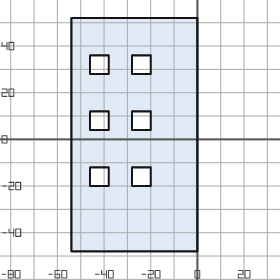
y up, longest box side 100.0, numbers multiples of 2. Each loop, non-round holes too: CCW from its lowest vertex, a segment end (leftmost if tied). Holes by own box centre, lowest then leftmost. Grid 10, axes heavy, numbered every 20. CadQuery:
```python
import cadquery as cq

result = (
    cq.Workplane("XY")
    .moveTo(-54.0, -48.0)
    .lineTo(0.0, -48.0)
    .lineTo(0.0, 52.0)
    .lineTo(-54.0, 52.0)
    .close()
    .moveTo(-46.0, -20.0)
    .lineTo(-38.0, -20.0)
    .lineTo(-38.0, -12.0)
    .lineTo(-46.0, -12.0)
    .close()
    .moveTo(-28.0, -20.0)
    .lineTo(-20.0, -20.0)
    .lineTo(-20.0, -12.0)
    .lineTo(-28.0, -12.0)
    .close()
    .moveTo(-46.0, 4.0)
    .lineTo(-38.0, 4.0)
    .lineTo(-38.0, 12.0)
    .lineTo(-46.0, 12.0)
    .close()
    .moveTo(-28.0, 4.0)
    .lineTo(-20.0, 4.0)
    .lineTo(-20.0, 12.0)
    .lineTo(-28.0, 12.0)
    .close()
    .moveTo(-46.0, 28.0)
    .lineTo(-38.0, 28.0)
    .lineTo(-38.0, 36.0)
    .lineTo(-46.0, 36.0)
    .close()
    .moveTo(-28.0, 28.0)
    .lineTo(-20.0, 28.0)
    .lineTo(-20.0, 36.0)
    .lineTo(-28.0, 36.0)
    .close()
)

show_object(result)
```